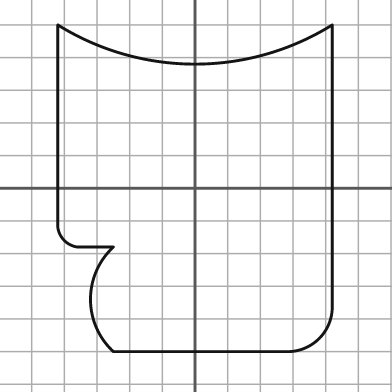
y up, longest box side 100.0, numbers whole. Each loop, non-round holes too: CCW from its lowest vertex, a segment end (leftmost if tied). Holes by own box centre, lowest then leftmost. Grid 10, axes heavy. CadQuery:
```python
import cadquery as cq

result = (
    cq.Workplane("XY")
    .moveTo(-25.0, -50.0)
    .lineTo(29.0, -50.0)
    .threePointArc((38.0, -46.0), (42.0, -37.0))
    .lineTo(42.0, 50.0)
    .threePointArc((0.0, 38.0), (-42.0, 50.0))
    .lineTo(-42.0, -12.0)
    .threePointArc((-40.0, -16.0), (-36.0, -18.0))
    .lineTo(-25.0, -18.0)
    .threePointArc((-32.0, -34.0), (-25.0, -50.0))
    .close()
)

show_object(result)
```